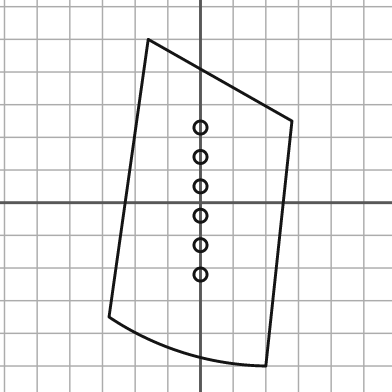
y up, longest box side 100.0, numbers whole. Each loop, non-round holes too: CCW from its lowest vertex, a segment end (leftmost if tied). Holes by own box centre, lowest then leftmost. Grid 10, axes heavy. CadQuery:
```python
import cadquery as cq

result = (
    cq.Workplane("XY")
    .moveTo(20.0, -50.0)
    .lineTo(28.0, 25.0)
    .lineTo(-16.0, 50.0)
    .lineTo(-28.0, -35.0)
    .threePointArc((-5.0, -46.0), (20.0, -50.0))
    .close()
    .moveTo(0.0, -22.0)
    .circle(2.0)
    .moveTo(0.0, -13.0)
    .circle(2.0)
    .moveTo(0.0, -4.0)
    .circle(2.0)
    .moveTo(0.0, 5.0)
    .circle(2.0)
    .moveTo(0.0, 14.0)
    .circle(2.0)
    .moveTo(0.0, 23.0)
    .circle(2.0)
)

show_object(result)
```